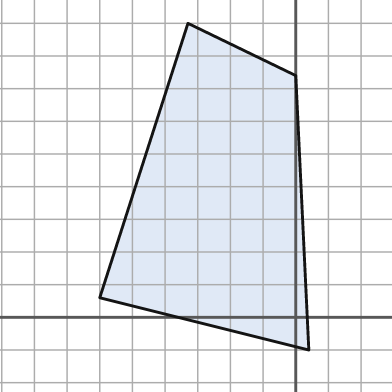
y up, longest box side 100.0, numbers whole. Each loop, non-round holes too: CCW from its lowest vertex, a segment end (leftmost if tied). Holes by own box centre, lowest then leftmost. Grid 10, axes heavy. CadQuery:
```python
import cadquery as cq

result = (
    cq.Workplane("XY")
    .moveTo(4.0, -10.0)
    .lineTo(0.0, 74.0)
    .lineTo(-33.0, 90.0)
    .lineTo(-60.0, 6.0)
    .close()
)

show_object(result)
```